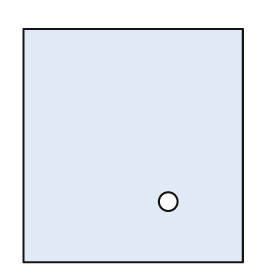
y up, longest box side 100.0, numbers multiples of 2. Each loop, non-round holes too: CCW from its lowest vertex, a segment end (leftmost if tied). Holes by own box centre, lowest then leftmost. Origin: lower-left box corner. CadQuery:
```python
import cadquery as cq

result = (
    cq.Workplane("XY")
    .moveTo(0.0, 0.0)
    .lineTo(94.0, 0.0)
    .lineTo(94.0, 100.0)
    .lineTo(0.0, 100.0)
    .close()
    .moveTo(62.0, 26.0)
    .circle(4.0)
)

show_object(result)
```